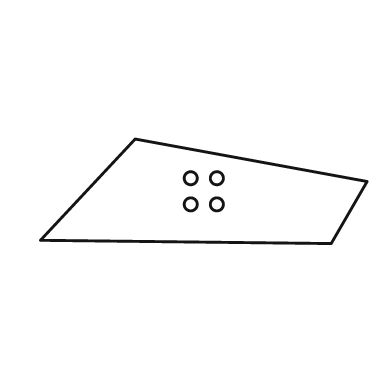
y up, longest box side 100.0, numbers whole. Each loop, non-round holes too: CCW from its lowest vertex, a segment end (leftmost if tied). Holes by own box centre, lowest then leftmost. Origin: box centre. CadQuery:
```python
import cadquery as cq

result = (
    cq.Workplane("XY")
    .moveTo(39.0, -16.0)
    .lineTo(50.0, 3.0)
    .lineTo(-21.0, 16.0)
    .lineTo(-50.0, -15.0)
    .close()
    .moveTo(-4.0, -4.0)
    .circle(2.0)
    .moveTo(4.0, -4.0)
    .circle(2.0)
    .moveTo(-4.0, 4.0)
    .circle(2.0)
    .moveTo(4.0, 4.0)
    .circle(2.0)
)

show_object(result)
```